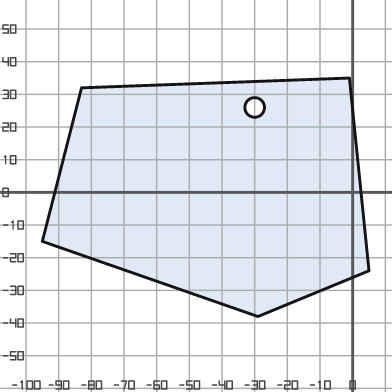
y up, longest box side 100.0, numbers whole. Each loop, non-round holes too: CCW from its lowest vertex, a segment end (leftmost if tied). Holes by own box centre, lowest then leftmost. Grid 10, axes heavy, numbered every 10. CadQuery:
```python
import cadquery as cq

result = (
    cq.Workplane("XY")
    .moveTo(-29.0, -38.0)
    .lineTo(5.0, -24.0)
    .lineTo(-1.0, 35.0)
    .lineTo(-83.0, 32.0)
    .lineTo(-95.0, -15.0)
    .close()
    .moveTo(-30.0, 26.0)
    .circle(3.0)
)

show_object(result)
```